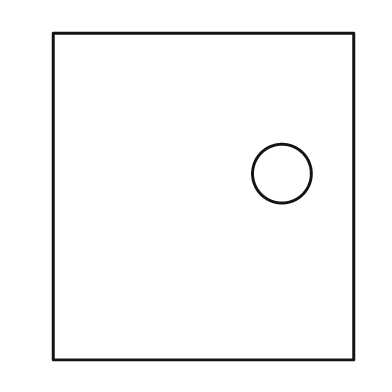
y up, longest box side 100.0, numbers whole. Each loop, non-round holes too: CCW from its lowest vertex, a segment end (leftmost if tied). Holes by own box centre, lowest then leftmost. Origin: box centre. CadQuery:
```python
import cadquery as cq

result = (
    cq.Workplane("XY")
    .moveTo(-46.0, -50.0)
    .lineTo(46.0, -50.0)
    .lineTo(46.0, 50.0)
    .lineTo(-46.0, 50.0)
    .close()
    .moveTo(24.0, 7.0)
    .circle(9.0)
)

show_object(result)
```